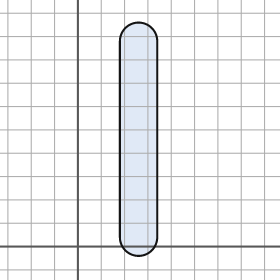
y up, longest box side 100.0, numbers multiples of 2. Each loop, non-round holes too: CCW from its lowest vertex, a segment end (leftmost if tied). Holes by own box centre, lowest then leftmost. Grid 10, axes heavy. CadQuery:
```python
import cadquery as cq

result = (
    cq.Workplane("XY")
    .moveTo(18.0, 4.0)
    .threePointArc((26.0, -4.0), (34.0, 4.0))
    .lineTo(34.0, 88.0)
    .threePointArc((26.0, 96.0), (18.0, 88.0))
    .close()
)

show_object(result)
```